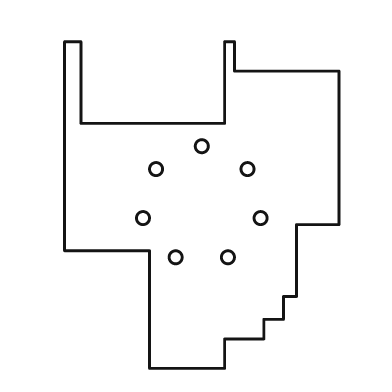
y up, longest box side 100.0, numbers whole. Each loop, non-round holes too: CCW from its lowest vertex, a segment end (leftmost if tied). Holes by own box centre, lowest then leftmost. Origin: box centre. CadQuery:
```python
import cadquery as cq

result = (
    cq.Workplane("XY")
    .moveTo(-16.0, -50.0)
    .lineTo(7.0, -50.0)
    .lineTo(7.0, -41.0)
    .lineTo(19.0, -41.0)
    .lineTo(19.0, -35.0)
    .lineTo(25.0, -35.0)
    .lineTo(25.0, -28.0)
    .lineTo(29.0, -28.0)
    .lineTo(29.0, -6.0)
    .lineTo(42.0, -6.0)
    .lineTo(42.0, 41.0)
    .lineTo(10.0, 41.0)
    .lineTo(10.0, 50.0)
    .lineTo(7.0, 50.0)
    .lineTo(7.0, 25.0)
    .lineTo(-37.0, 25.0)
    .lineTo(-37.0, 50.0)
    .lineTo(-42.0, 50.0)
    .lineTo(-42.0, -14.0)
    .lineTo(-16.0, -14.0)
    .close()
    .moveTo(-8.0, -16.0)
    .circle(2.0)
    .moveTo(8.0, -16.0)
    .circle(2.0)
    .moveTo(-18.0, -4.0)
    .circle(2.0)
    .moveTo(18.0, -4.0)
    .circle(2.0)
    .moveTo(-14.0, 11.0)
    .circle(2.0)
    .moveTo(14.0, 11.0)
    .circle(2.0)
    .moveTo(0.0, 18.0)
    .circle(2.0)
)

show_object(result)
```